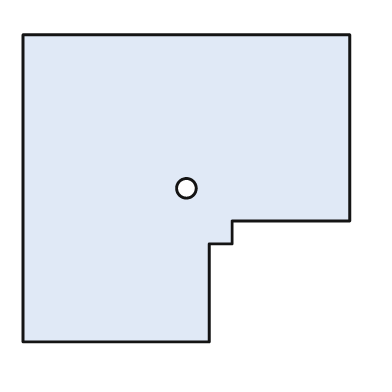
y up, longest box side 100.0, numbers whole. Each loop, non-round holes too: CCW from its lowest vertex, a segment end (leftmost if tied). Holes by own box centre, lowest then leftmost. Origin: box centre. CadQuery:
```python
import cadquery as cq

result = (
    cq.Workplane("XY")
    .moveTo(-50.0, -47.0)
    .lineTo(7.0, -47.0)
    .lineTo(7.0, -17.0)
    .lineTo(14.0, -17.0)
    .lineTo(14.0, -10.0)
    .lineTo(50.0, -10.0)
    .lineTo(50.0, 47.0)
    .lineTo(-50.0, 47.0)
    .close()
    .moveTo(0.0, 0.0)
    .circle(3.0)
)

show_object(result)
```